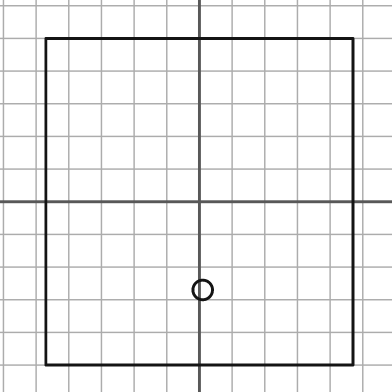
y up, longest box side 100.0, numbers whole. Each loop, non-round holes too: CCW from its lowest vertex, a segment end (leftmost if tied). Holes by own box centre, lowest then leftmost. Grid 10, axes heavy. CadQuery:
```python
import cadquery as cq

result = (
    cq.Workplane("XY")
    .moveTo(-47.0, -50.0)
    .lineTo(47.0, -50.0)
    .lineTo(47.0, 50.0)
    .lineTo(-47.0, 50.0)
    .close()
    .moveTo(1.0, -27.0)
    .circle(3.0)
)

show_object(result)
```